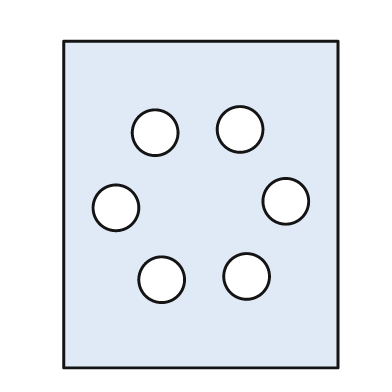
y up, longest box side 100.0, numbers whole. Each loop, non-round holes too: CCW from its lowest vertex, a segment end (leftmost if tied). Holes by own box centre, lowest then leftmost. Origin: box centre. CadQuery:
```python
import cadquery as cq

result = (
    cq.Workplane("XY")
    .moveTo(-42.0, -50.0)
    .lineTo(42.0, -50.0)
    .lineTo(42.0, 50.0)
    .lineTo(-42.0, 50.0)
    .close()
    .moveTo(-12.0, -23.0)
    .circle(7.0)
    .moveTo(14.0, -22.0)
    .circle(7.0)
    .moveTo(-26.0, -1.0)
    .circle(7.0)
    .moveTo(26.0, 1.0)
    .circle(7.0)
    .moveTo(-14.0, 22.0)
    .circle(7.0)
    .moveTo(12.0, 23.0)
    .circle(7.0)
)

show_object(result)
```